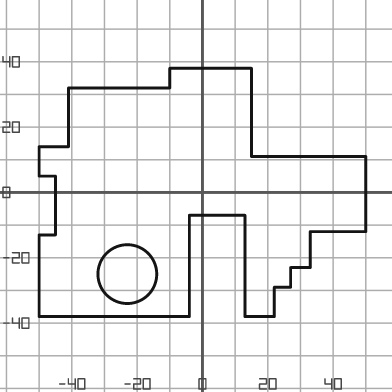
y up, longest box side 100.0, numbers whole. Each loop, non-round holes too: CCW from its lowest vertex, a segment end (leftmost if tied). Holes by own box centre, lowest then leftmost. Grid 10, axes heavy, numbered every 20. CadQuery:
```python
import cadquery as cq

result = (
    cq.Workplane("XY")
    .moveTo(-50.0, -38.0)
    .lineTo(-4.0, -38.0)
    .lineTo(-4.0, -7.0)
    .lineTo(13.0, -7.0)
    .lineTo(13.0, -38.0)
    .lineTo(22.0, -38.0)
    .lineTo(22.0, -29.0)
    .lineTo(27.0, -29.0)
    .lineTo(27.0, -23.0)
    .lineTo(33.0, -23.0)
    .lineTo(33.0, -12.0)
    .lineTo(50.0, -12.0)
    .lineTo(50.0, 11.0)
    .lineTo(15.0, 11.0)
    .lineTo(15.0, 38.0)
    .lineTo(-10.0, 38.0)
    .lineTo(-10.0, 32.0)
    .lineTo(-41.0, 32.0)
    .lineTo(-41.0, 14.0)
    .lineTo(-50.0, 14.0)
    .lineTo(-50.0, 5.0)
    .lineTo(-45.0, 5.0)
    .lineTo(-45.0, -13.0)
    .lineTo(-50.0, -13.0)
    .close()
    .moveTo(-23.0, -25.0)
    .circle(9.0)
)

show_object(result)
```